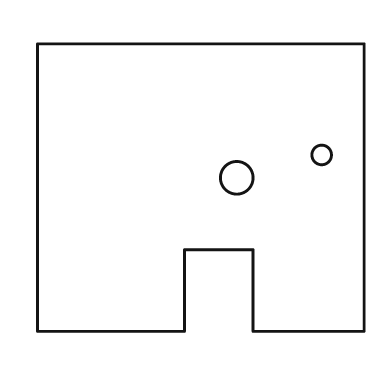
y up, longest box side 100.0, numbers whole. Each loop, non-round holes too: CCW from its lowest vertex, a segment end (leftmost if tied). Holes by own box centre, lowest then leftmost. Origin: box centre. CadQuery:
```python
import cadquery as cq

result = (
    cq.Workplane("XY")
    .moveTo(-50.0, -44.0)
    .lineTo(-5.0, -44.0)
    .lineTo(-5.0, -19.0)
    .lineTo(16.0, -19.0)
    .lineTo(16.0, -44.0)
    .lineTo(50.0, -44.0)
    .lineTo(50.0, 44.0)
    .lineTo(-50.0, 44.0)
    .close()
    .moveTo(11.0, 3.0)
    .circle(5.0)
    .moveTo(37.0, 10.0)
    .circle(3.0)
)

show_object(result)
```